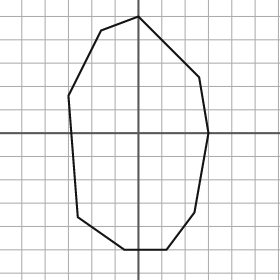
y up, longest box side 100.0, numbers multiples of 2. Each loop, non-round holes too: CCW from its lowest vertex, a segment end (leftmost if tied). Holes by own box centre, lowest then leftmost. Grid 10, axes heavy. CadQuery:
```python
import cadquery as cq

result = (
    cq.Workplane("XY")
    .moveTo(-6.0, -50.0)
    .lineTo(12.0, -50.0)
    .lineTo(24.0, -34.0)
    .lineTo(30.0, 0.0)
    .lineTo(26.0, 24.0)
    .lineTo(0.0, 50.0)
    .lineTo(-16.0, 44.0)
    .lineTo(-30.0, 16.0)
    .lineTo(-26.0, -36.0)
    .close()
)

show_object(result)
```